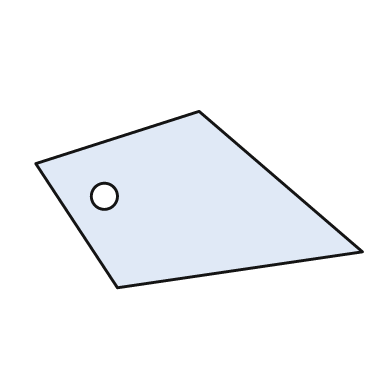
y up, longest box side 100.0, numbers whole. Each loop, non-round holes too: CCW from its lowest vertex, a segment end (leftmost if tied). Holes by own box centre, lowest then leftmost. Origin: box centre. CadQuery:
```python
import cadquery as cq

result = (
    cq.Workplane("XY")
    .moveTo(-25.0, -27.0)
    .lineTo(50.0, -16.0)
    .lineTo(0.0, 27.0)
    .lineTo(-50.0, 11.0)
    .close()
    .moveTo(-29.0, 1.0)
    .circle(4.0)
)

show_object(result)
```